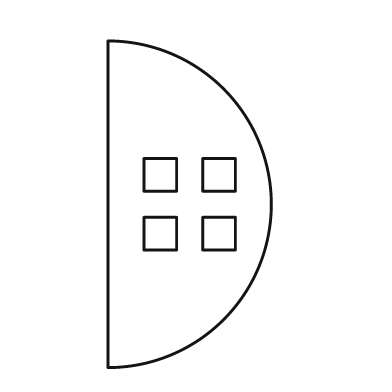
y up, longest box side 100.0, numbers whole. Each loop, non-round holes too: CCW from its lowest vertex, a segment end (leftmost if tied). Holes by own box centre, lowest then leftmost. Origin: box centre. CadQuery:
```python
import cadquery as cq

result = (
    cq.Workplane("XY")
    .moveTo(-25.0, -50.0)
    .threePointArc((25.0, 0.0), (-25.0, 50.0))
    .close()
    .moveTo(-14.0, -14.0)
    .lineTo(-4.0, -14.0)
    .lineTo(-4.0, -4.0)
    .lineTo(-14.0, -4.0)
    .close()
    .moveTo(4.0, -14.0)
    .lineTo(14.0, -14.0)
    .lineTo(14.0, -4.0)
    .lineTo(4.0, -4.0)
    .close()
    .moveTo(-14.0, 4.0)
    .lineTo(-4.0, 4.0)
    .lineTo(-4.0, 14.0)
    .lineTo(-14.0, 14.0)
    .close()
    .moveTo(4.0, 4.0)
    .lineTo(14.0, 4.0)
    .lineTo(14.0, 14.0)
    .lineTo(4.0, 14.0)
    .close()
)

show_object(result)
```